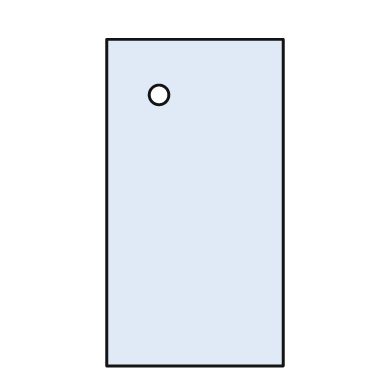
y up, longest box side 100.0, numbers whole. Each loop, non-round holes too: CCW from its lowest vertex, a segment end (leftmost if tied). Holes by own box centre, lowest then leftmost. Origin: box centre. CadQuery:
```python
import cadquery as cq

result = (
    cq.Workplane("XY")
    .moveTo(-27.0, -50.0)
    .lineTo(27.0, -50.0)
    .lineTo(27.0, 50.0)
    .lineTo(-27.0, 50.0)
    .close()
    .moveTo(-11.0, 33.0)
    .circle(3.0)
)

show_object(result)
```